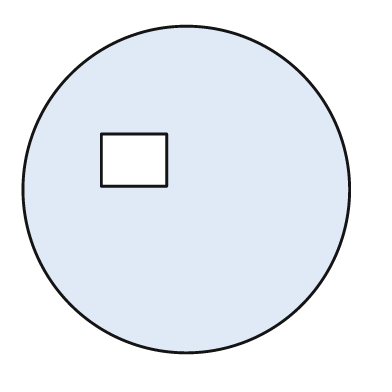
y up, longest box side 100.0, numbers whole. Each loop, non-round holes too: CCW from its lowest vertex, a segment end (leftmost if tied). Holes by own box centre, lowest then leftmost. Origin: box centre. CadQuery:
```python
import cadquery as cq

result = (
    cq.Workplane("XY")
    .moveTo(0.0, 0.0)
    .circle(50.0)
    .moveTo(-26.0, 1.0)
    .lineTo(-6.0, 1.0)
    .lineTo(-6.0, 17.0)
    .lineTo(-26.0, 17.0)
    .close()
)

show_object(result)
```